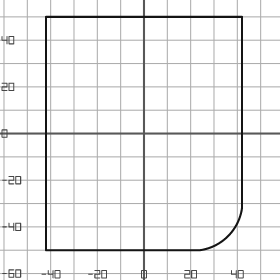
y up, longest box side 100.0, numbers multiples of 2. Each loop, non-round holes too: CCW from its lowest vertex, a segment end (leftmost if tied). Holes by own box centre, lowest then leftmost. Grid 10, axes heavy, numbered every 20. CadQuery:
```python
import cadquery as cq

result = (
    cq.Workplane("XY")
    .moveTo(-42.0, -50.0)
    .lineTo(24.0, -50.0)
    .threePointArc((36.0, -44.0), (42.0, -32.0))
    .lineTo(42.0, 50.0)
    .lineTo(-42.0, 50.0)
    .close()
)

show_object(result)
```